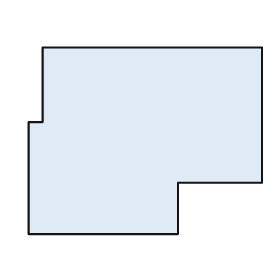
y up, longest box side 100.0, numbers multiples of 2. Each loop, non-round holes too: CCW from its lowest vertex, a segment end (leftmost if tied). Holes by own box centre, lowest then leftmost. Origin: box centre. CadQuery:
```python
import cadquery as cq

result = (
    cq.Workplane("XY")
    .moveTo(-50.0, -40.0)
    .lineTo(14.0, -40.0)
    .lineTo(14.0, -18.0)
    .lineTo(50.0, -18.0)
    .lineTo(50.0, 40.0)
    .lineTo(-44.0, 40.0)
    .lineTo(-44.0, 8.0)
    .lineTo(-50.0, 8.0)
    .close()
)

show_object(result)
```